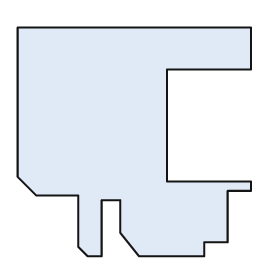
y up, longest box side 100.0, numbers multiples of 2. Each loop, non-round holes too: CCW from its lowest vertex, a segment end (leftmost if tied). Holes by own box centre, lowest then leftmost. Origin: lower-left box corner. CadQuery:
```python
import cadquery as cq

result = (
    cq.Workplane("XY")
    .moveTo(30.0, 0.0)
    .lineTo(36.0, 0.0)
    .lineTo(36.0, 24.0)
    .lineTo(44.0, 24.0)
    .lineTo(44.0, 10.0)
    .lineTo(52.0, 0.0)
    .lineTo(80.0, 0.0)
    .lineTo(80.0, 6.0)
    .lineTo(90.0, 6.0)
    .lineTo(90.0, 28.0)
    .lineTo(100.0, 28.0)
    .lineTo(100.0, 32.0)
    .lineTo(64.0, 32.0)
    .lineTo(64.0, 80.0)
    .lineTo(100.0, 80.0)
    .lineTo(100.0, 98.0)
    .lineTo(0.0, 98.0)
    .lineTo(0.0, 34.0)
    .lineTo(8.0, 26.0)
    .lineTo(26.0, 26.0)
    .lineTo(26.0, 4.0)
    .close()
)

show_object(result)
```